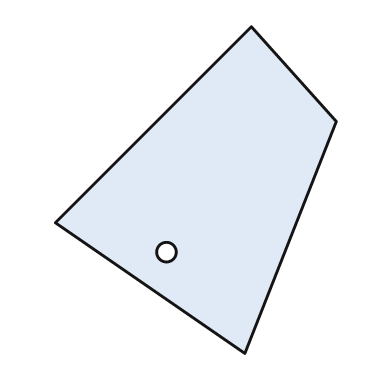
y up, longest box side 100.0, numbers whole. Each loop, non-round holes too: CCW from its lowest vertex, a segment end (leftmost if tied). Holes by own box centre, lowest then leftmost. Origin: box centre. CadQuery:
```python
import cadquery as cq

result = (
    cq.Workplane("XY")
    .moveTo(15.0, -50.0)
    .lineTo(43.0, 21.0)
    .lineTo(17.0, 50.0)
    .lineTo(-43.0, -10.0)
    .close()
    .moveTo(-9.0, -19.0)
    .circle(3.0)
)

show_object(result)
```